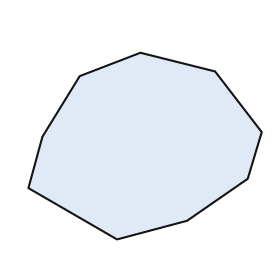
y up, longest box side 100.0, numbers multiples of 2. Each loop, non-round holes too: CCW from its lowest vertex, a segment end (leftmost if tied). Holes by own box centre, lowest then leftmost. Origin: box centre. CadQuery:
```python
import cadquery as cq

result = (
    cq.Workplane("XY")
    .moveTo(-12.0, -40.0)
    .lineTo(18.0, -32.0)
    .lineTo(44.0, -14.0)
    .lineTo(50.0, 6.0)
    .lineTo(30.0, 32.0)
    .lineTo(-2.0, 40.0)
    .lineTo(-28.0, 30.0)
    .lineTo(-44.0, 4.0)
    .lineTo(-50.0, -18.0)
    .close()
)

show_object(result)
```